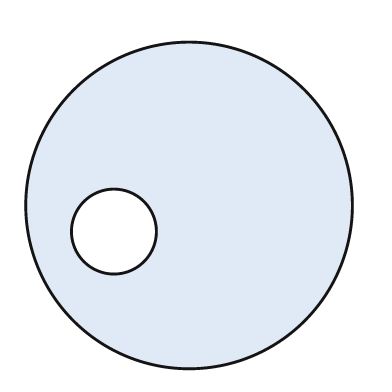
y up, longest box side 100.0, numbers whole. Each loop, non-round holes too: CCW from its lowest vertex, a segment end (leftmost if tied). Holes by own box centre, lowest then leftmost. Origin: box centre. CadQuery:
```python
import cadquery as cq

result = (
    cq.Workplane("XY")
    .moveTo(0.0, 0.0)
    .circle(50.0)
    .moveTo(-23.0, -8.0)
    .circle(13.0)
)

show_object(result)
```